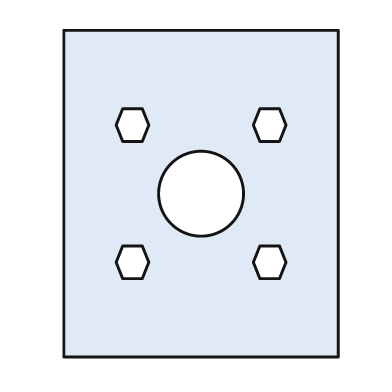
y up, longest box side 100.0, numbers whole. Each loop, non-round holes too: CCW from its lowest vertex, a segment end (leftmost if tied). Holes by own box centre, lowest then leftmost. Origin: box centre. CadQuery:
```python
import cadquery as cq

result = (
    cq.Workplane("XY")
    .moveTo(-42.0, -50.0)
    .lineTo(42.0, -50.0)
    .lineTo(42.0, 50.0)
    .lineTo(-42.0, 50.0)
    .close()
    .moveTo(-24.0, -26.0)
    .lineTo(-18.0, -26.0)
    .lineTo(-16.0, -21.0)
    .lineTo(-18.0, -16.0)
    .lineTo(-24.0, -16.0)
    .lineTo(-26.0, -21.0)
    .close()
    .moveTo(18.0, -26.0)
    .lineTo(24.0, -26.0)
    .lineTo(26.0, -21.0)
    .lineTo(24.0, -16.0)
    .lineTo(18.0, -16.0)
    .lineTo(16.0, -21.0)
    .close()
    .moveTo(0.0, 0.0)
    .circle(13.0)
    .moveTo(-24.0, 16.0)
    .lineTo(-18.0, 16.0)
    .lineTo(-16.0, 21.0)
    .lineTo(-18.0, 26.0)
    .lineTo(-24.0, 26.0)
    .lineTo(-26.0, 21.0)
    .close()
    .moveTo(18.0, 16.0)
    .lineTo(24.0, 16.0)
    .lineTo(26.0, 21.0)
    .lineTo(24.0, 26.0)
    .lineTo(18.0, 26.0)
    .lineTo(16.0, 21.0)
    .close()
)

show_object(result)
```